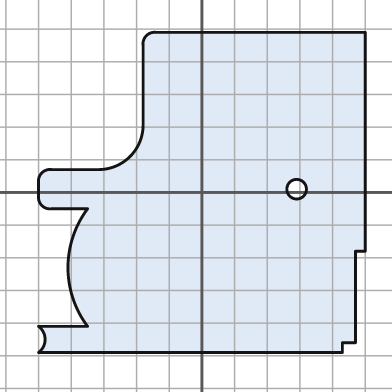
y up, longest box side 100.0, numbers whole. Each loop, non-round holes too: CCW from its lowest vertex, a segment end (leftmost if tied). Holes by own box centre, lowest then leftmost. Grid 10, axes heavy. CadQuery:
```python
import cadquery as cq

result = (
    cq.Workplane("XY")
    .moveTo(-50.0, -49.0)
    .lineTo(43.0, -49.0)
    .lineTo(43.0, -46.0)
    .lineTo(47.0, -46.0)
    .lineTo(47.0, -18.0)
    .lineTo(50.0, -18.0)
    .lineTo(50.0, 49.0)
    .lineTo(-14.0, 49.0)
    .threePointArc((-17.0, 48.0), (-18.0, 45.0))
    .lineTo(-18.0, 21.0)
    .threePointArc((-22.0, 11.0), (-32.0, 7.0))
    .lineTo(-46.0, 7.0)
    .threePointArc((-49.0, 6.0), (-50.0, 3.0))
    .lineTo(-50.0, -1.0)
    .threePointArc((-49.0, -4.0), (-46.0, -5.0))
    .lineTo(-35.0, -5.0)
    .threePointArc((-41.0, -23.0), (-35.0, -41.0))
    .lineTo(-50.0, -41.0)
    .threePointArc((-48.0, -45.0), (-50.0, -49.0))
    .close()
    .moveTo(29.0, 1.0)
    .circle(3.0)
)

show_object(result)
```